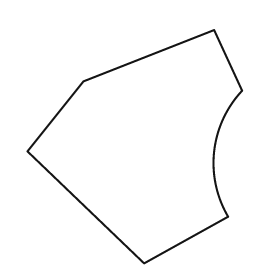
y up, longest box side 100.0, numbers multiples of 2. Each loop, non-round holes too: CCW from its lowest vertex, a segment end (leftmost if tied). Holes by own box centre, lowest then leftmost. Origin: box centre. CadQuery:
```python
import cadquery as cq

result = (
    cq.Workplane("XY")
    .moveTo(4.0, -50.0)
    .lineTo(40.0, -30.0)
    .threePointArc((34.0, -2.0), (46.0, 24.0))
    .lineTo(34.0, 50.0)
    .lineTo(-22.0, 28.0)
    .lineTo(-46.0, -2.0)
    .close()
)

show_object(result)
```